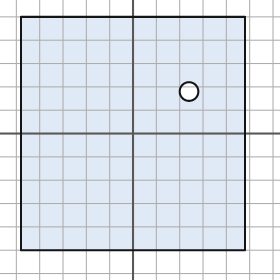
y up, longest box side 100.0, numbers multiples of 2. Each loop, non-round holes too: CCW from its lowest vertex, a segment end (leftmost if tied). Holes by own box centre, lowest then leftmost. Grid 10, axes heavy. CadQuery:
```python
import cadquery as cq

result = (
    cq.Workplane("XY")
    .moveTo(-48.0, -50.0)
    .lineTo(48.0, -50.0)
    .lineTo(48.0, 50.0)
    .lineTo(-48.0, 50.0)
    .close()
    .moveTo(24.0, 18.0)
    .circle(4.0)
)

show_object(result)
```